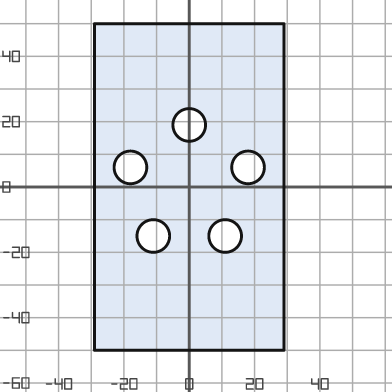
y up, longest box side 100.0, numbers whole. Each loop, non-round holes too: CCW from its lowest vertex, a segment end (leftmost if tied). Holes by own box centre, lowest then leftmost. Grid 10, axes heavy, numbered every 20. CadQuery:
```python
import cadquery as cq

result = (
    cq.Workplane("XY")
    .moveTo(-29.0, -50.0)
    .lineTo(29.0, -50.0)
    .lineTo(29.0, 50.0)
    .lineTo(-29.0, 50.0)
    .close()
    .moveTo(-11.0, -15.0)
    .circle(5.0)
    .moveTo(11.0, -15.0)
    .circle(5.0)
    .moveTo(-18.0, 6.0)
    .circle(5.0)
    .moveTo(18.0, 6.0)
    .circle(5.0)
    .moveTo(0.0, 19.0)
    .circle(5.0)
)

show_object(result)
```